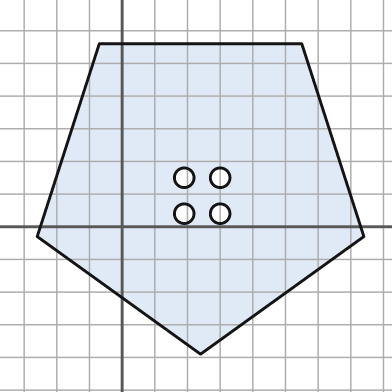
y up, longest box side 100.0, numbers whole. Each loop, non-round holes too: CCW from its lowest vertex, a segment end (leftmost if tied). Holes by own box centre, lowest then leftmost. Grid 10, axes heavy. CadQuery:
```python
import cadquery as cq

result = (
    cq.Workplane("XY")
    .moveTo(24.0, -39.0)
    .lineTo(74.0, -3.0)
    .lineTo(55.0, 56.0)
    .lineTo(-7.0, 56.0)
    .lineTo(-26.0, -3.0)
    .close()
    .moveTo(19.0, 4.0)
    .circle(3.0)
    .moveTo(30.0, 4.0)
    .circle(3.0)
    .moveTo(19.0, 15.0)
    .circle(3.0)
    .moveTo(30.0, 15.0)
    .circle(3.0)
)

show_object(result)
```